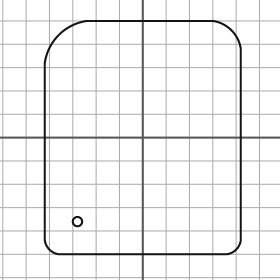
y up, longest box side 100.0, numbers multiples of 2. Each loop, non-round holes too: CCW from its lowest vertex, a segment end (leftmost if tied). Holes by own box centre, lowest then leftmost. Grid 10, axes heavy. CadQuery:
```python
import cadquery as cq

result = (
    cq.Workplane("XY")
    .moveTo(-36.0, -50.0)
    .lineTo(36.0, -50.0)
    .threePointArc((40.0, -48.0), (42.0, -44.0))
    .lineTo(42.0, 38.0)
    .threePointArc((38.0, 46.0), (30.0, 50.0))
    .lineTo(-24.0, 50.0)
    .threePointArc((-36.0, 44.0), (-42.0, 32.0))
    .lineTo(-42.0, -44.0)
    .threePointArc((-40.0, -48.0), (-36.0, -50.0))
    .close()
    .moveTo(-28.0, -36.0)
    .circle(2.0)
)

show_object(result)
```